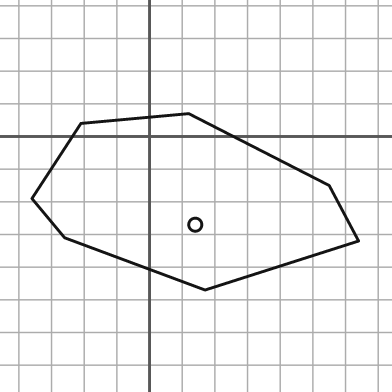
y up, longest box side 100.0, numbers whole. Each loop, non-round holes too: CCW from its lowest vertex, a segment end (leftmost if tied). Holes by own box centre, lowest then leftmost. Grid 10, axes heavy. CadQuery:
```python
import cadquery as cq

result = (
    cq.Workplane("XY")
    .moveTo(17.0, -47.0)
    .lineTo(64.0, -32.0)
    .lineTo(55.0, -15.0)
    .lineTo(12.0, 7.0)
    .lineTo(-21.0, 4.0)
    .lineTo(-36.0, -19.0)
    .lineTo(-26.0, -31.0)
    .close()
    .moveTo(14.0, -27.0)
    .circle(2.0)
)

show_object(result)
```